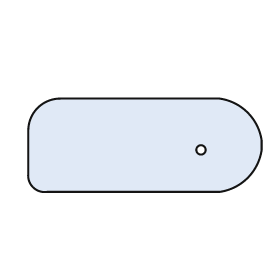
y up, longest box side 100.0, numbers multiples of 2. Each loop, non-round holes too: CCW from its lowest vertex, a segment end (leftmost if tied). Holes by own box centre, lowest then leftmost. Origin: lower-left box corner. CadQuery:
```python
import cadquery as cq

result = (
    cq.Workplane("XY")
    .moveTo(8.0, 0.0)
    .lineTo(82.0, 0.0)
    .threePointArc((94.0, 6.0), (100.0, 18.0))
    .lineTo(100.0, 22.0)
    .threePointArc((94.0, 34.0), (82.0, 40.0))
    .lineTo(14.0, 40.0)
    .threePointArc((4.0, 36.0), (0.0, 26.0))
    .lineTo(0.0, 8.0)
    .threePointArc((2.0, 2.0), (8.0, 0.0))
    .close()
    .moveTo(74.0, 18.0)
    .circle(2.0)
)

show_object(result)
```